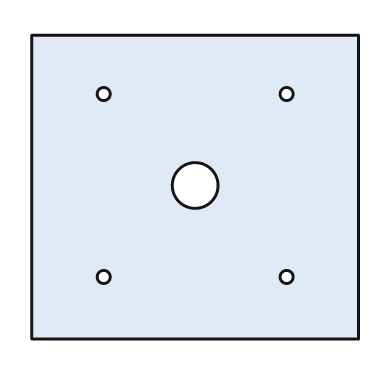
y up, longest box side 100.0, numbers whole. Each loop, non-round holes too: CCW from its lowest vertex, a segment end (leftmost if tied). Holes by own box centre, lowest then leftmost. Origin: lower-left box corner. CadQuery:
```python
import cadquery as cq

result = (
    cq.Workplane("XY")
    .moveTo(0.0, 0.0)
    .lineTo(100.0, 0.0)
    .lineTo(100.0, 93.0)
    .lineTo(0.0, 93.0)
    .close()
    .moveTo(22.0, 19.0)
    .circle(2.0)
    .moveTo(78.0, 19.0)
    .circle(2.0)
    .moveTo(50.0, 47.0)
    .circle(7.0)
    .moveTo(22.0, 75.0)
    .circle(2.0)
    .moveTo(78.0, 75.0)
    .circle(2.0)
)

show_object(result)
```